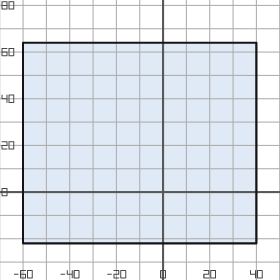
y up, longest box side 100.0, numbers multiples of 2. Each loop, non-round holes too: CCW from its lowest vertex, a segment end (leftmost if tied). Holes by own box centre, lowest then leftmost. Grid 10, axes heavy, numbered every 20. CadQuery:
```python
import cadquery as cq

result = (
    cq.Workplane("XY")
    .moveTo(-60.0, -22.0)
    .lineTo(40.0, -22.0)
    .lineTo(40.0, 64.0)
    .lineTo(-60.0, 64.0)
    .close()
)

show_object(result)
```